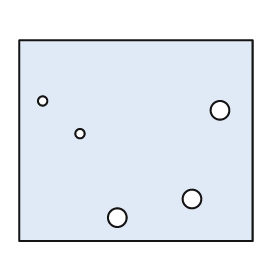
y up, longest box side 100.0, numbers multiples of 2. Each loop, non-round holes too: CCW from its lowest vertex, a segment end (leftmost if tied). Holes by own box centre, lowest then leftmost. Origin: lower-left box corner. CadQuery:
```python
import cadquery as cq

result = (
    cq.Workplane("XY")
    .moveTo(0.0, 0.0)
    .lineTo(100.0, 0.0)
    .lineTo(100.0, 86.0)
    .lineTo(0.0, 86.0)
    .close()
    .moveTo(42.0, 10.0)
    .circle(4.0)
    .moveTo(74.0, 18.0)
    .circle(4.0)
    .moveTo(26.0, 46.0)
    .circle(2.0)
    .moveTo(86.0, 56.0)
    .circle(4.0)
    .moveTo(10.0, 60.0)
    .circle(2.0)
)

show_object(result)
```